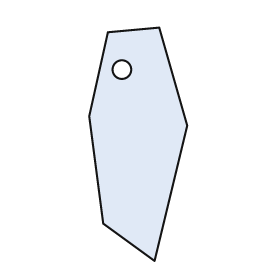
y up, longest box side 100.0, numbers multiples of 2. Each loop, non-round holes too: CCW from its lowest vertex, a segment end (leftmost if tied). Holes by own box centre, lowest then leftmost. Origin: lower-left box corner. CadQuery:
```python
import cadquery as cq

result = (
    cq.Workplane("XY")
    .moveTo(28.0, 0.0)
    .lineTo(42.0, 58.0)
    .lineTo(30.0, 100.0)
    .lineTo(8.0, 98.0)
    .lineTo(0.0, 62.0)
    .lineTo(6.0, 16.0)
    .close()
    .moveTo(14.0, 82.0)
    .circle(4.0)
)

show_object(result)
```